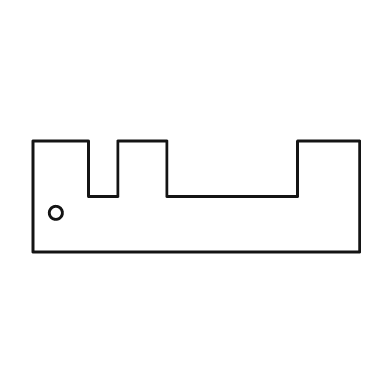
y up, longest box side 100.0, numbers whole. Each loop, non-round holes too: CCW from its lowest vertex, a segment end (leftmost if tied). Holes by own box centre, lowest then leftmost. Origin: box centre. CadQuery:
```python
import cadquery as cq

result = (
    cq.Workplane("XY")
    .moveTo(-50.0, -17.0)
    .lineTo(50.0, -17.0)
    .lineTo(50.0, 17.0)
    .lineTo(31.0, 17.0)
    .lineTo(31.0, 0.0)
    .lineTo(-9.0, 0.0)
    .lineTo(-9.0, 17.0)
    .lineTo(-24.0, 17.0)
    .lineTo(-24.0, 0.0)
    .lineTo(-33.0, 0.0)
    .lineTo(-33.0, 17.0)
    .lineTo(-50.0, 17.0)
    .close()
    .moveTo(-43.0, -5.0)
    .circle(2.0)
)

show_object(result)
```